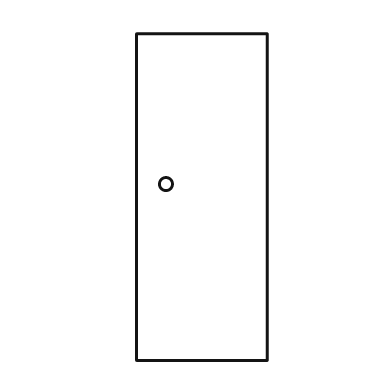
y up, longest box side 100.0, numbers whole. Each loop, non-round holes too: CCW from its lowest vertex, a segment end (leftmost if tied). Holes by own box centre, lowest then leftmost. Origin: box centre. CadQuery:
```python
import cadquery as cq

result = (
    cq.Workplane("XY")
    .moveTo(-20.0, -50.0)
    .lineTo(20.0, -50.0)
    .lineTo(20.0, 50.0)
    .lineTo(-20.0, 50.0)
    .close()
    .moveTo(-11.0, 4.0)
    .circle(2.0)
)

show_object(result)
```